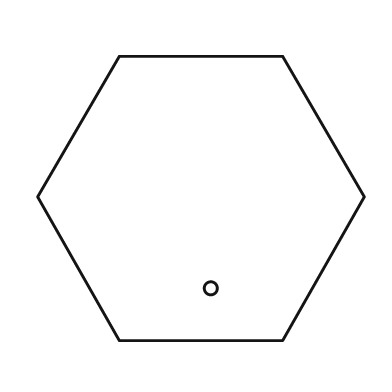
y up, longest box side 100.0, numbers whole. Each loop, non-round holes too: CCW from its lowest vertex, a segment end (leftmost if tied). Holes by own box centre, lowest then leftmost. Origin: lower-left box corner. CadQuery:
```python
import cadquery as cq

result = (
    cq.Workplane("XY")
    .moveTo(25.0, 0.0)
    .lineTo(75.0, 0.0)
    .lineTo(100.0, 44.0)
    .lineTo(75.0, 87.0)
    .lineTo(25.0, 87.0)
    .lineTo(0.0, 44.0)
    .close()
    .moveTo(53.0, 16.0)
    .circle(2.0)
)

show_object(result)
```